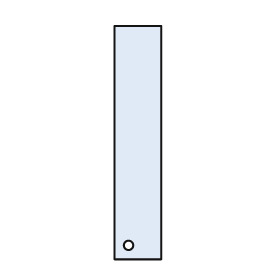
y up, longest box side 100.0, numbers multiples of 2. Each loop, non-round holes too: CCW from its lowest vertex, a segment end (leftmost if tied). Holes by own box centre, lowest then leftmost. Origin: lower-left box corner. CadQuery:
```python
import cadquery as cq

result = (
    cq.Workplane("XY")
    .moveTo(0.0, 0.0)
    .lineTo(20.0, 0.0)
    .lineTo(20.0, 100.0)
    .lineTo(0.0, 100.0)
    .close()
    .moveTo(6.0, 6.0)
    .circle(2.0)
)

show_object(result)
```